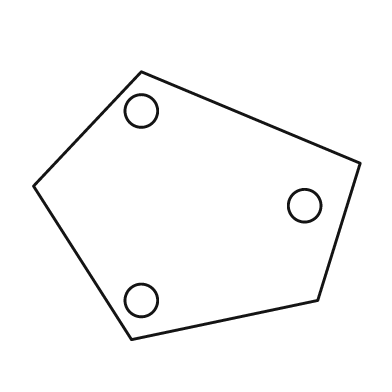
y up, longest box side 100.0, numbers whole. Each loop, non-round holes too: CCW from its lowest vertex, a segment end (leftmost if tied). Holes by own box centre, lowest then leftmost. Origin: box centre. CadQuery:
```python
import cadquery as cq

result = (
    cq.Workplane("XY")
    .moveTo(-20.0, -41.0)
    .lineTo(37.0, -29.0)
    .lineTo(50.0, 13.0)
    .lineTo(-17.0, 41.0)
    .lineTo(-50.0, 6.0)
    .close()
    .moveTo(-17.0, -29.0)
    .circle(5.0)
    .moveTo(33.0, 0.0)
    .circle(5.0)
    .moveTo(-17.0, 29.0)
    .circle(5.0)
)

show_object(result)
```